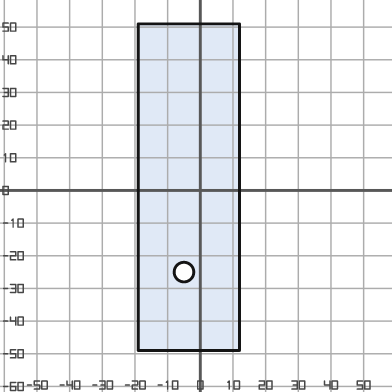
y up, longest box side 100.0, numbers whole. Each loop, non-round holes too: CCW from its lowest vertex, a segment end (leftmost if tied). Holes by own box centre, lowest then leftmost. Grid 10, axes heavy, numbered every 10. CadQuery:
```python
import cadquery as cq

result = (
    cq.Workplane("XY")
    .moveTo(-19.0, -49.0)
    .lineTo(12.0, -49.0)
    .lineTo(12.0, 51.0)
    .lineTo(-19.0, 51.0)
    .close()
    .moveTo(-5.0, -25.0)
    .circle(3.0)
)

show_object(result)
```